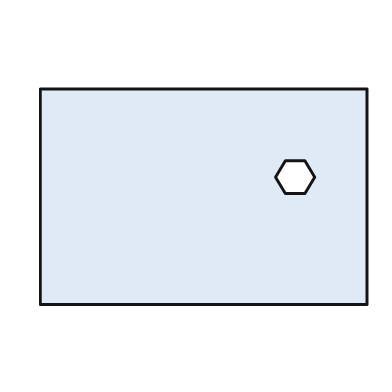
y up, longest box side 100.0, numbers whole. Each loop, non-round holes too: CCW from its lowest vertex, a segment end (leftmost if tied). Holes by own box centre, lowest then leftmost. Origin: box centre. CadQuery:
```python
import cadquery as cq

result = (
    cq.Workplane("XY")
    .moveTo(-50.0, -33.0)
    .lineTo(50.0, -33.0)
    .lineTo(50.0, 33.0)
    .lineTo(-50.0, 33.0)
    .close()
    .moveTo(25.0, 1.0)
    .lineTo(31.0, 1.0)
    .lineTo(34.0, 6.0)
    .lineTo(31.0, 11.0)
    .lineTo(25.0, 11.0)
    .lineTo(22.0, 6.0)
    .close()
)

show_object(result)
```